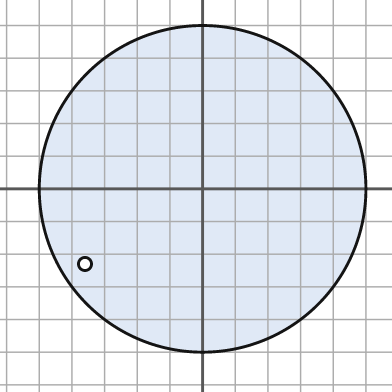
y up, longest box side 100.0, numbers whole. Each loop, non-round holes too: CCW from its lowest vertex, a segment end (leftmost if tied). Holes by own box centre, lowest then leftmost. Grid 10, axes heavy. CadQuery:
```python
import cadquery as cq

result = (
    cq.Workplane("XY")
    .moveTo(0.0, 0.0)
    .circle(50.0)
    .moveTo(-36.0, -23.0)
    .circle(2.0)
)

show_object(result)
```